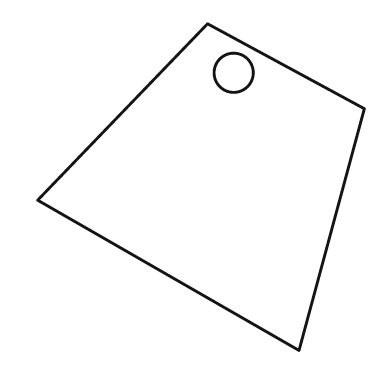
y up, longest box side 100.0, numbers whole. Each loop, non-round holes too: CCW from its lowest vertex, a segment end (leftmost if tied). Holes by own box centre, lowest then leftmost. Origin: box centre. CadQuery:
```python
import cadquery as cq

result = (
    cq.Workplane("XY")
    .moveTo(30.0, -50.0)
    .lineTo(50.0, 24.0)
    .lineTo(2.0, 50.0)
    .lineTo(-50.0, -4.0)
    .close()
    .moveTo(10.0, 35.0)
    .circle(6.0)
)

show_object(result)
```